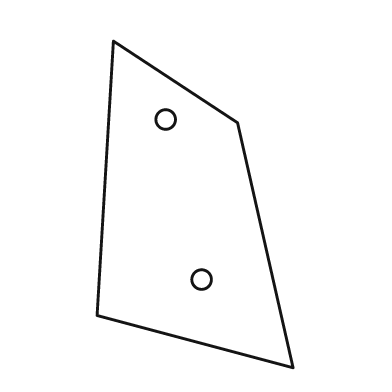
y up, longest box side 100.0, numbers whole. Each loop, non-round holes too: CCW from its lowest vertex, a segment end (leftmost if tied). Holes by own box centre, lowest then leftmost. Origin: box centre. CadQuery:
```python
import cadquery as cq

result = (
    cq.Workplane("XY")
    .moveTo(30.0, -50.0)
    .lineTo(13.0, 25.0)
    .lineTo(-25.0, 50.0)
    .lineTo(-30.0, -34.0)
    .close()
    .moveTo(2.0, -23.0)
    .circle(3.0)
    .moveTo(-9.0, 26.0)
    .circle(3.0)
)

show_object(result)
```